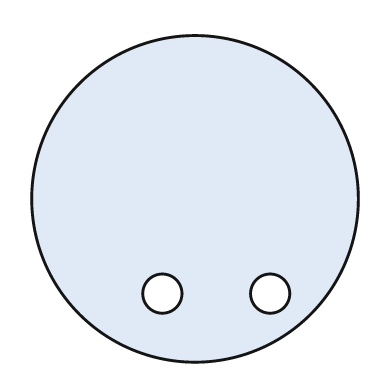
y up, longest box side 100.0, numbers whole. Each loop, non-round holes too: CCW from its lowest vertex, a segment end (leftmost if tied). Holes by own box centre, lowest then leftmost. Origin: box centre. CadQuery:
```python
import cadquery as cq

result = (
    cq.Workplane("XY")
    .moveTo(0.0, 0.0)
    .circle(50.0)
    .moveTo(-10.0, -29.0)
    .circle(6.0)
    .moveTo(23.0, -29.0)
    .circle(6.0)
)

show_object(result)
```